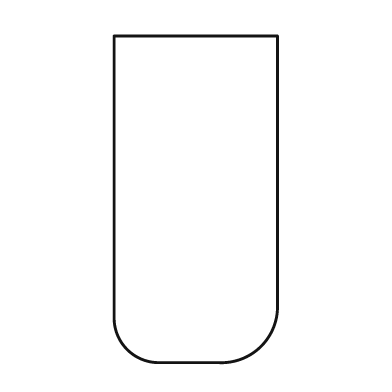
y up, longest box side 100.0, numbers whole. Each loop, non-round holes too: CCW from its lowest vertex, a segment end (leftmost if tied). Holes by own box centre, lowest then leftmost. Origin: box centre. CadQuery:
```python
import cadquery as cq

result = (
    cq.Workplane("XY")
    .moveTo(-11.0, -50.0)
    .lineTo(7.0, -50.0)
    .threePointArc((20.0, -45.0), (25.0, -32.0))
    .lineTo(25.0, 50.0)
    .lineTo(-25.0, 50.0)
    .lineTo(-25.0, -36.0)
    .threePointArc((-21.0, -46.0), (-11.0, -50.0))
    .close()
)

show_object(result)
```